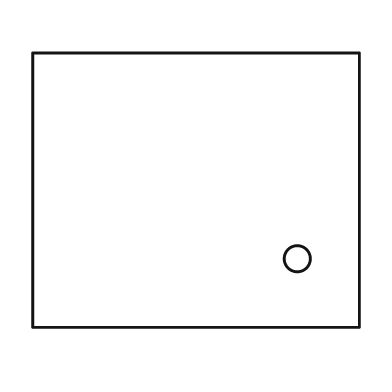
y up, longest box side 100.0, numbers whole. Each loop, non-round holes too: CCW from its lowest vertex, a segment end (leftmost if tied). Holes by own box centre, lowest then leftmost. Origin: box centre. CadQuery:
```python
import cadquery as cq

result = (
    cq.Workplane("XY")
    .moveTo(-50.0, -42.0)
    .lineTo(50.0, -42.0)
    .lineTo(50.0, 42.0)
    .lineTo(-50.0, 42.0)
    .close()
    .moveTo(31.0, -21.0)
    .circle(4.0)
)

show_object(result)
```